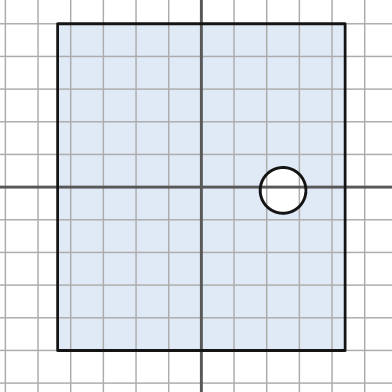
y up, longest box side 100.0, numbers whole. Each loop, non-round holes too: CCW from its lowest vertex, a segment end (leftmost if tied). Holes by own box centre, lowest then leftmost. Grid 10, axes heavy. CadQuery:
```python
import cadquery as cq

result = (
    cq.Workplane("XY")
    .moveTo(-44.0, -50.0)
    .lineTo(44.0, -50.0)
    .lineTo(44.0, 50.0)
    .lineTo(-44.0, 50.0)
    .close()
    .moveTo(25.0, -1.0)
    .circle(7.0)
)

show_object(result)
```